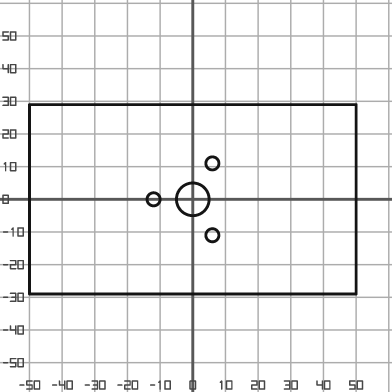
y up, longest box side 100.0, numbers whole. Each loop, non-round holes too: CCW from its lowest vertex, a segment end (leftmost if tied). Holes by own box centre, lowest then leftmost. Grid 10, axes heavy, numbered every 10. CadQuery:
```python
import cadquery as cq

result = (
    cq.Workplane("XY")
    .moveTo(-50.0, -29.0)
    .lineTo(50.0, -29.0)
    .lineTo(50.0, 29.0)
    .lineTo(-50.0, 29.0)
    .close()
    .moveTo(6.0, -11.0)
    .circle(2.0)
    .moveTo(-12.0, 0.0)
    .circle(2.0)
    .moveTo(0.0, 0.0)
    .circle(5.0)
    .moveTo(6.0, 11.0)
    .circle(2.0)
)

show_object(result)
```